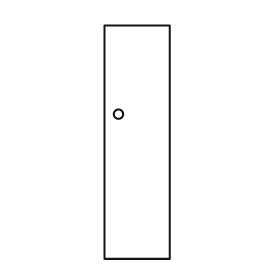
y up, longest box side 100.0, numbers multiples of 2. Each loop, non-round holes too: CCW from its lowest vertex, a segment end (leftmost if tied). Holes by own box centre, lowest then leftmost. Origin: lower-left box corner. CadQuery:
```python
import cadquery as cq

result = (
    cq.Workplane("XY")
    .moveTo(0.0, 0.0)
    .lineTo(28.0, 0.0)
    .lineTo(28.0, 100.0)
    .lineTo(0.0, 100.0)
    .close()
    .moveTo(6.0, 62.0)
    .circle(2.0)
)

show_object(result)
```